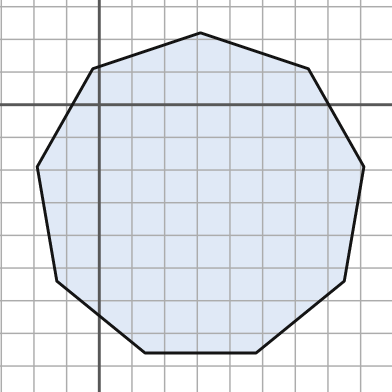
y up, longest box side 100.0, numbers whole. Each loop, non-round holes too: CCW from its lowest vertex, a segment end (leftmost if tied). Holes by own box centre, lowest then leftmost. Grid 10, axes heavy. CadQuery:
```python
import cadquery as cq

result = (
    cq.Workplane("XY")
    .moveTo(14.0, -76.0)
    .lineTo(48.0, -76.0)
    .lineTo(75.0, -54.0)
    .lineTo(81.0, -19.0)
    .lineTo(64.0, 11.0)
    .lineTo(31.0, 22.0)
    .lineTo(-2.0, 11.0)
    .lineTo(-19.0, -19.0)
    .lineTo(-13.0, -54.0)
    .close()
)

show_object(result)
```